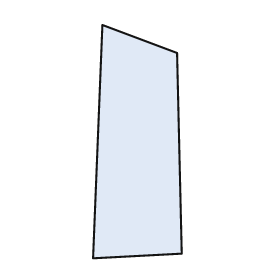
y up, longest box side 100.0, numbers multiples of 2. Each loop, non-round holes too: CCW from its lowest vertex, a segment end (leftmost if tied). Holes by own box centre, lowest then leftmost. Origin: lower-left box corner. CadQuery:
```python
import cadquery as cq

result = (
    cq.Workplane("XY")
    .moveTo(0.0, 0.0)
    .lineTo(38.0, 2.0)
    .lineTo(36.0, 88.0)
    .lineTo(4.0, 100.0)
    .close()
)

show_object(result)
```